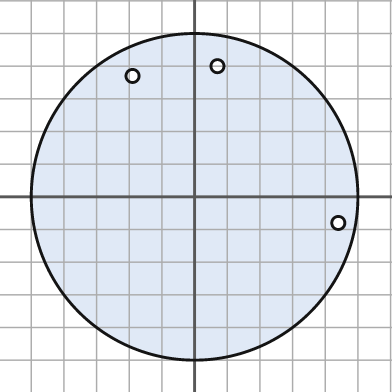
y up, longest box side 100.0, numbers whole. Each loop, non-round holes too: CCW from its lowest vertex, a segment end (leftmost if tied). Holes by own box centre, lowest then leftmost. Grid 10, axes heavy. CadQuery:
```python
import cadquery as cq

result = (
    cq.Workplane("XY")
    .moveTo(0.0, 0.0)
    .circle(50.0)
    .moveTo(44.0, -8.0)
    .circle(2.0)
    .moveTo(-19.0, 37.0)
    .circle(2.0)
    .moveTo(7.0, 40.0)
    .circle(2.0)
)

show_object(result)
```